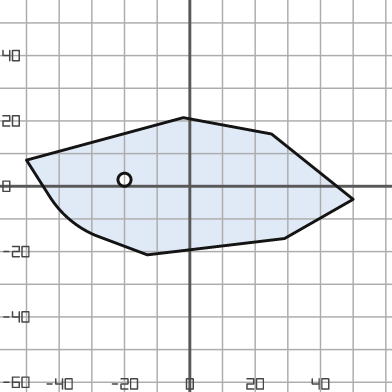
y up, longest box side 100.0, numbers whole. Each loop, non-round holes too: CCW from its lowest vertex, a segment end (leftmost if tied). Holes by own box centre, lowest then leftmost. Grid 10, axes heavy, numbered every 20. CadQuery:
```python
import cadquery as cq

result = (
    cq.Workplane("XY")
    .moveTo(-13.0, -21.0)
    .lineTo(29.0, -16.0)
    .lineTo(50.0, -4.0)
    .lineTo(25.0, 16.0)
    .lineTo(-2.0, 21.0)
    .lineTo(-50.0, 8.0)
    .lineTo(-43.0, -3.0)
    .threePointArc((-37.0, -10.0), (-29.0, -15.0))
    .close()
    .moveTo(-20.0, 2.0)
    .circle(2.0)
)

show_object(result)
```